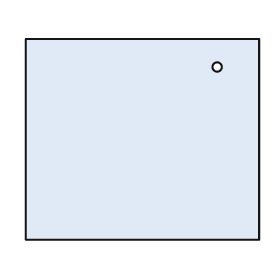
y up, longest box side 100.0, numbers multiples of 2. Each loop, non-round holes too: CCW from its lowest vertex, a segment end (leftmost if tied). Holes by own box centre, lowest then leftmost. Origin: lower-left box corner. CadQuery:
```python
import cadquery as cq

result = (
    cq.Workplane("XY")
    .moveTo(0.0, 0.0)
    .lineTo(100.0, 0.0)
    .lineTo(100.0, 86.0)
    .lineTo(0.0, 86.0)
    .close()
    .moveTo(82.0, 74.0)
    .circle(2.0)
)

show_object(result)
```